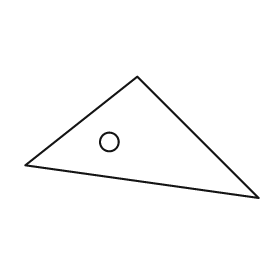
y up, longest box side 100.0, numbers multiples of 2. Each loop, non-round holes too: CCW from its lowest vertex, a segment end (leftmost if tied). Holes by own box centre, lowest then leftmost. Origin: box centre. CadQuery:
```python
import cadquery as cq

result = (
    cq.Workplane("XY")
    .moveTo(50.0, -26.0)
    .lineTo(-2.0, 26.0)
    .lineTo(-50.0, -12.0)
    .close()
    .moveTo(-14.0, -2.0)
    .circle(4.0)
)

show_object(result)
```